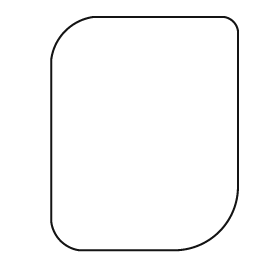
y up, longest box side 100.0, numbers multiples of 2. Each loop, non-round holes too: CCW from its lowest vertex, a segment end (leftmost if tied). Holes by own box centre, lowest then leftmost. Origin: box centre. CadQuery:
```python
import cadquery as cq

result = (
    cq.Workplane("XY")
    .moveTo(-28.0, -50.0)
    .lineTo(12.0, -50.0)
    .threePointArc((32.0, -42.0), (40.0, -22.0))
    .lineTo(40.0, 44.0)
    .threePointArc((38.0, 48.0), (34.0, 50.0))
    .lineTo(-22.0, 50.0)
    .threePointArc((-34.0, 44.0), (-40.0, 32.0))
    .lineTo(-40.0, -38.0)
    .threePointArc((-36.0, -46.0), (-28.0, -50.0))
    .close()
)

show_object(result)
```